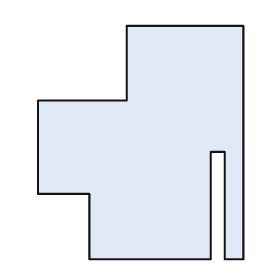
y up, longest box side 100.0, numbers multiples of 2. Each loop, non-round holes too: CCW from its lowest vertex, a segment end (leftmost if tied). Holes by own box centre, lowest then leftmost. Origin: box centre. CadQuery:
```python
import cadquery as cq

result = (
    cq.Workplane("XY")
    .moveTo(-22.0, -50.0)
    .lineTo(30.0, -50.0)
    .lineTo(30.0, -4.0)
    .lineTo(36.0, -4.0)
    .lineTo(36.0, -50.0)
    .lineTo(44.0, -50.0)
    .lineTo(44.0, 50.0)
    .lineTo(-6.0, 50.0)
    .lineTo(-6.0, 18.0)
    .lineTo(-44.0, 18.0)
    .lineTo(-44.0, -22.0)
    .lineTo(-22.0, -22.0)
    .close()
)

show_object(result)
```